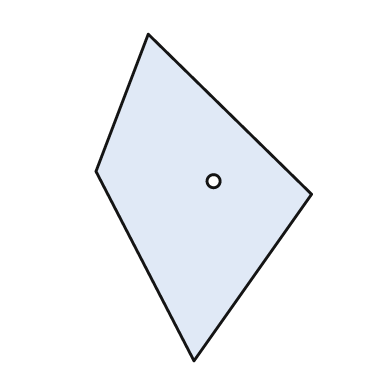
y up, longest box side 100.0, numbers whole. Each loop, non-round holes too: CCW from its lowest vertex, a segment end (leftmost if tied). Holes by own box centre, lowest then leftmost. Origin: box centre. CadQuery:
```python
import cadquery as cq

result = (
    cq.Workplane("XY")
    .moveTo(-3.0, -50.0)
    .lineTo(33.0, 1.0)
    .lineTo(-17.0, 50.0)
    .lineTo(-33.0, 8.0)
    .close()
    .moveTo(3.0, 5.0)
    .circle(2.0)
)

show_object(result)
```